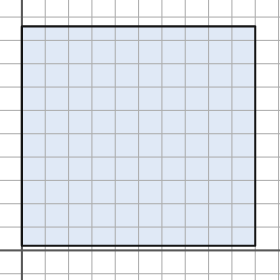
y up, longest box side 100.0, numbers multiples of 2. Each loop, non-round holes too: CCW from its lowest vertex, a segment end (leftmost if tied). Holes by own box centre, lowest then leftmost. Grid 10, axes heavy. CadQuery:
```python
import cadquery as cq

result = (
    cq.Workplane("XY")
    .moveTo(0.0, 2.0)
    .lineTo(100.0, 2.0)
    .lineTo(100.0, 96.0)
    .lineTo(0.0, 96.0)
    .close()
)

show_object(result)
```